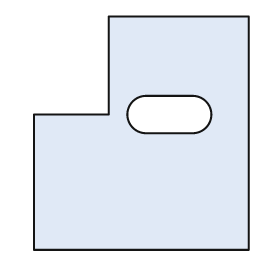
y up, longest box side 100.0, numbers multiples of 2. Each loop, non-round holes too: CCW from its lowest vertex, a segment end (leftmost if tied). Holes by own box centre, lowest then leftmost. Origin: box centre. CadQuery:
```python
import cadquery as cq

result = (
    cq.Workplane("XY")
    .moveTo(-46.0, -50.0)
    .lineTo(46.0, -50.0)
    .lineTo(46.0, 50.0)
    .lineTo(-14.0, 50.0)
    .lineTo(-14.0, 8.0)
    .lineTo(-46.0, 8.0)
    .close()
    .moveTo(2.0, 0.0)
    .lineTo(22.0, 0.0)
    .threePointArc((30.0, 8.0), (22.0, 16.0))
    .lineTo(2.0, 16.0)
    .threePointArc((-6.0, 8.0), (2.0, 0.0))
    .close()
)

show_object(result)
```